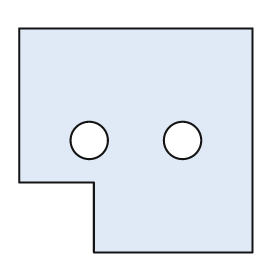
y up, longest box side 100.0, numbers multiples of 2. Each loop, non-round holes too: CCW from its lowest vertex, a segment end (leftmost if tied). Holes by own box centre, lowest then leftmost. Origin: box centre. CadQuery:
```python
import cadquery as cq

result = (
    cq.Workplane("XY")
    .moveTo(-18.0, -48.0)
    .lineTo(50.0, -48.0)
    .lineTo(50.0, 48.0)
    .lineTo(-50.0, 48.0)
    .lineTo(-50.0, -18.0)
    .lineTo(-18.0, -18.0)
    .close()
    .moveTo(-20.0, 0.0)
    .circle(8.0)
    .moveTo(20.0, 0.0)
    .circle(8.0)
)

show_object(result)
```